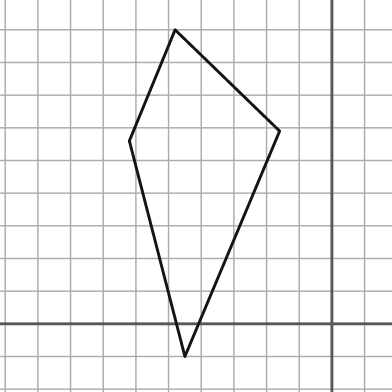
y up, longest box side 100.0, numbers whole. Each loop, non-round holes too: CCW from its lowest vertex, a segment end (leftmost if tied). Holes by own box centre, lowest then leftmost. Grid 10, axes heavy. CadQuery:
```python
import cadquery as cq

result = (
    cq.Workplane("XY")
    .moveTo(-45.0, -10.0)
    .lineTo(-16.0, 59.0)
    .lineTo(-48.0, 90.0)
    .lineTo(-62.0, 56.0)
    .close()
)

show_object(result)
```